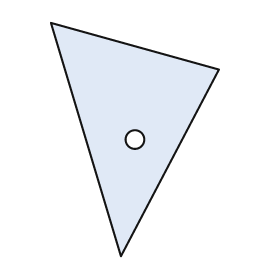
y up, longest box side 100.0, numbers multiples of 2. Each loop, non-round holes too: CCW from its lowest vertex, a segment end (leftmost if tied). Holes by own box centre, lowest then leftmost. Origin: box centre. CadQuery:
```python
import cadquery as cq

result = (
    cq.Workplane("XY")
    .moveTo(-6.0, -50.0)
    .lineTo(36.0, 30.0)
    .lineTo(-36.0, 50.0)
    .close()
    .moveTo(0.0, 0.0)
    .circle(4.0)
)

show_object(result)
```